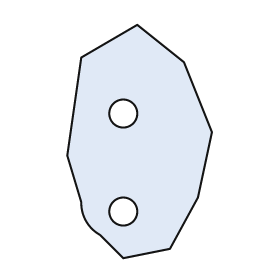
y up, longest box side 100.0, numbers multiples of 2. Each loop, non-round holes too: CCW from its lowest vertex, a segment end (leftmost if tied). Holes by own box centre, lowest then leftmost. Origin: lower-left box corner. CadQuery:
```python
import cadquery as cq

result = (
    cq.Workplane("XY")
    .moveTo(24.0, 0.0)
    .lineTo(44.0, 4.0)
    .lineTo(56.0, 26.0)
    .lineTo(62.0, 54.0)
    .lineTo(50.0, 84.0)
    .lineTo(30.0, 100.0)
    .lineTo(6.0, 86.0)
    .lineTo(0.0, 44.0)
    .lineTo(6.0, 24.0)
    .threePointArc((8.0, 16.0), (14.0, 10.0))
    .close()
    .moveTo(24.0, 20.0)
    .circle(6.0)
    .moveTo(24.0, 62.0)
    .circle(6.0)
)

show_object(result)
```